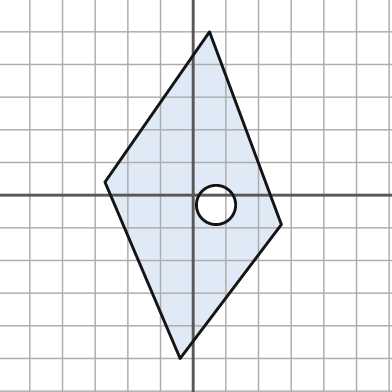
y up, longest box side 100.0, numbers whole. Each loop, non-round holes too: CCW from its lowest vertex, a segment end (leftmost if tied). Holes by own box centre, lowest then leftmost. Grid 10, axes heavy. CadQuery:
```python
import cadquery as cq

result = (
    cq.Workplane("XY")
    .moveTo(-4.0, -50.0)
    .lineTo(27.0, -9.0)
    .lineTo(5.0, 50.0)
    .lineTo(-27.0, 4.0)
    .close()
    .moveTo(7.0, -3.0)
    .circle(6.0)
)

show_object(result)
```